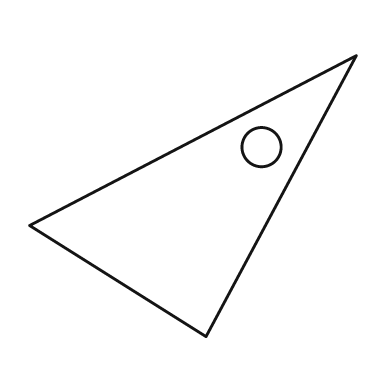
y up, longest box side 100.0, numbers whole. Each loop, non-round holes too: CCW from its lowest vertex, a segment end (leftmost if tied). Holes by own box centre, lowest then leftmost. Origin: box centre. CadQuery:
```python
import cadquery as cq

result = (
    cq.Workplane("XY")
    .moveTo(4.0, -43.0)
    .lineTo(50.0, 43.0)
    .lineTo(-50.0, -9.0)
    .close()
    .moveTo(21.0, 15.0)
    .circle(6.0)
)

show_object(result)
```